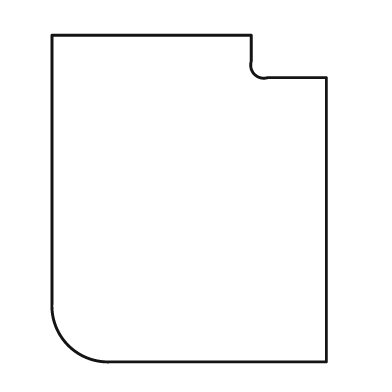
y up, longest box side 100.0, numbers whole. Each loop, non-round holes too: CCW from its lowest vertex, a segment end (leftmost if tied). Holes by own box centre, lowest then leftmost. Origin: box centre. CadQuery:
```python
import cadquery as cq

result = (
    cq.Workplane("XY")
    .moveTo(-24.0, -50.0)
    .lineTo(42.0, -50.0)
    .lineTo(42.0, 37.0)
    .lineTo(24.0, 37.0)
    .threePointArc((20.0, 38.0), (19.0, 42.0))
    .lineTo(19.0, 50.0)
    .lineTo(-42.0, 50.0)
    .lineTo(-42.0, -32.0)
    .threePointArc((-37.0, -45.0), (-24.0, -50.0))
    .close()
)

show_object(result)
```